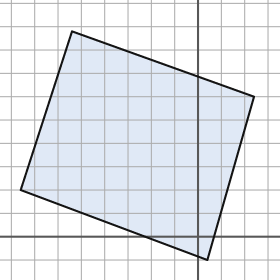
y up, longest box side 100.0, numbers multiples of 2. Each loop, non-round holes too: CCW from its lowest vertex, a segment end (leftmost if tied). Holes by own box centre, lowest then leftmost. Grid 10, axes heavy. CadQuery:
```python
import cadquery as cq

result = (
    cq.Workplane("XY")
    .moveTo(4.0, -10.0)
    .lineTo(24.0, 60.0)
    .lineTo(-54.0, 88.0)
    .lineTo(-76.0, 20.0)
    .close()
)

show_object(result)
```